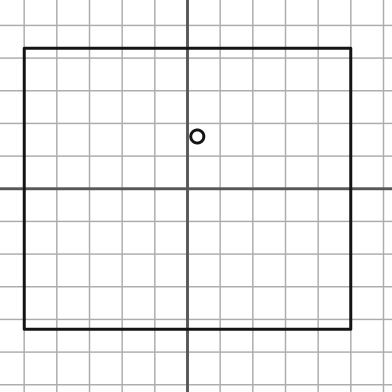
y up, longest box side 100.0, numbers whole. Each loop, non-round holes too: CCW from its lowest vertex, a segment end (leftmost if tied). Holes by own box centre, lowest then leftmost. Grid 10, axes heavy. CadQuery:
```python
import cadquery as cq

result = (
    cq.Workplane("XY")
    .moveTo(-50.0, -43.0)
    .lineTo(50.0, -43.0)
    .lineTo(50.0, 43.0)
    .lineTo(-50.0, 43.0)
    .close()
    .moveTo(3.0, 16.0)
    .circle(2.0)
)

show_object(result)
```